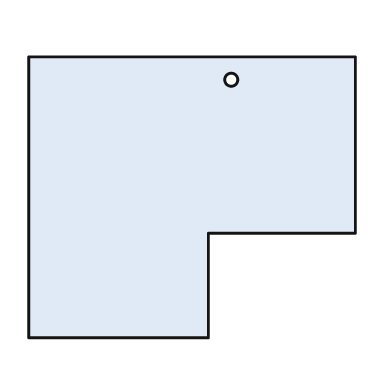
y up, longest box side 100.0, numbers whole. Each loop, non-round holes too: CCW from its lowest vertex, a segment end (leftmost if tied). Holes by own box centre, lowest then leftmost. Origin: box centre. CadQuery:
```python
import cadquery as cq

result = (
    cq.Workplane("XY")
    .moveTo(-50.0, -43.0)
    .lineTo(5.0, -43.0)
    .lineTo(5.0, -11.0)
    .lineTo(50.0, -11.0)
    .lineTo(50.0, 43.0)
    .lineTo(-50.0, 43.0)
    .close()
    .moveTo(12.0, 36.0)
    .circle(2.0)
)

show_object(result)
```